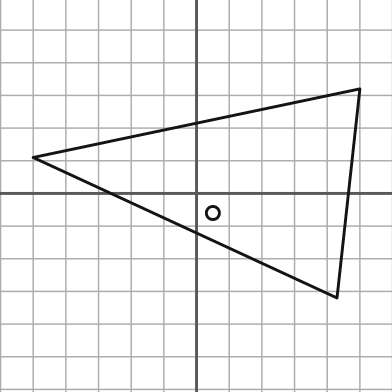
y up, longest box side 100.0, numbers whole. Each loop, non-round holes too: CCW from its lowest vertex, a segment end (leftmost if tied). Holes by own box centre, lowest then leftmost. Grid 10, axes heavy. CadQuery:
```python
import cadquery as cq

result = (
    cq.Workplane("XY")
    .moveTo(43.0, -32.0)
    .lineTo(50.0, 32.0)
    .lineTo(-50.0, 11.0)
    .close()
    .moveTo(5.0, -6.0)
    .circle(2.0)
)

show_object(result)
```